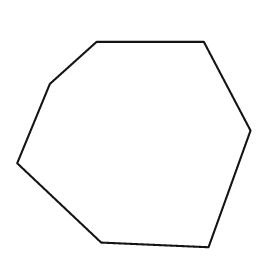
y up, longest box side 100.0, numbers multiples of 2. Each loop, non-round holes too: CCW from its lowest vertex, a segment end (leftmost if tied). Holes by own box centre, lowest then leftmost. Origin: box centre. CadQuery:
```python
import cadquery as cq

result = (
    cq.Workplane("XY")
    .moveTo(32.0, -44.0)
    .lineTo(50.0, 6.0)
    .lineTo(30.0, 44.0)
    .lineTo(-16.0, 44.0)
    .lineTo(-36.0, 26.0)
    .lineTo(-50.0, -8.0)
    .lineTo(-14.0, -42.0)
    .close()
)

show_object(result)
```